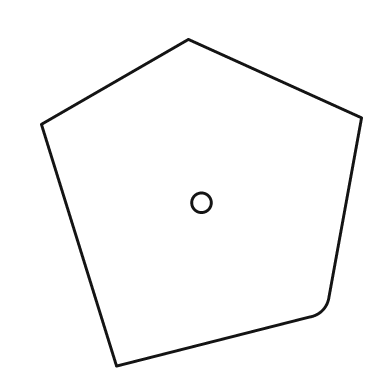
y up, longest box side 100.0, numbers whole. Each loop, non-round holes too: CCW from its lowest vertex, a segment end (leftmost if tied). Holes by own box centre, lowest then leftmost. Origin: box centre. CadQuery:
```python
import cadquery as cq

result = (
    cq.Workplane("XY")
    .moveTo(-26.0, -50.0)
    .lineTo(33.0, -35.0)
    .threePointArc((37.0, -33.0), (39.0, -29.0))
    .lineTo(49.0, 26.0)
    .lineTo(-4.0, 50.0)
    .lineTo(-49.0, 24.0)
    .close()
    .moveTo(0.0, 0.0)
    .circle(3.0)
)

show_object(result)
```